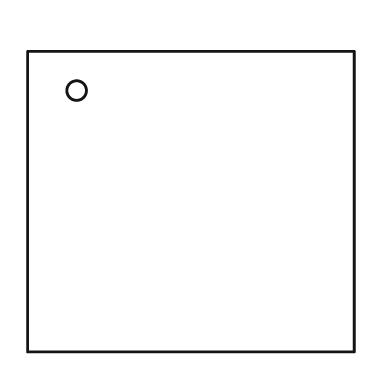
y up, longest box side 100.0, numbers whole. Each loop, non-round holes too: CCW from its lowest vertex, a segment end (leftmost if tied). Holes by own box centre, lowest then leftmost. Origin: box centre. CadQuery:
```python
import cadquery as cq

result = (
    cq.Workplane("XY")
    .moveTo(-50.0, -46.0)
    .lineTo(50.0, -46.0)
    .lineTo(50.0, 46.0)
    .lineTo(-50.0, 46.0)
    .close()
    .moveTo(-35.0, 34.0)
    .circle(3.0)
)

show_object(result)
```